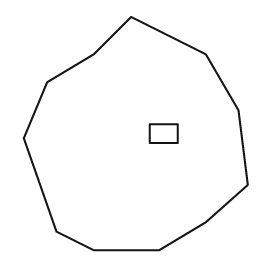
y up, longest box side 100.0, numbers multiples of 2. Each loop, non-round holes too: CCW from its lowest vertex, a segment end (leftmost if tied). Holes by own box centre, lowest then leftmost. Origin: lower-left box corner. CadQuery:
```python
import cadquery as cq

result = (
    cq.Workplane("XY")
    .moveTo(30.0, 0.0)
    .lineTo(58.0, 0.0)
    .lineTo(78.0, 12.0)
    .lineTo(96.0, 28.0)
    .lineTo(92.0, 60.0)
    .lineTo(78.0, 84.0)
    .lineTo(46.0, 100.0)
    .lineTo(30.0, 84.0)
    .lineTo(10.0, 72.0)
    .lineTo(0.0, 48.0)
    .lineTo(14.0, 8.0)
    .close()
    .moveTo(54.0, 46.0)
    .lineTo(66.0, 46.0)
    .lineTo(66.0, 54.0)
    .lineTo(54.0, 54.0)
    .close()
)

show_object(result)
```